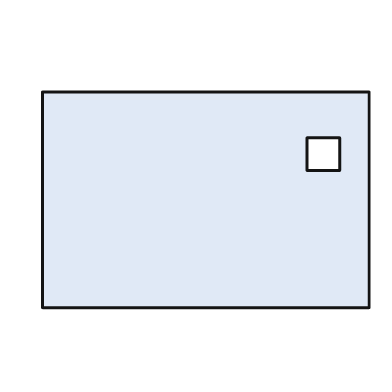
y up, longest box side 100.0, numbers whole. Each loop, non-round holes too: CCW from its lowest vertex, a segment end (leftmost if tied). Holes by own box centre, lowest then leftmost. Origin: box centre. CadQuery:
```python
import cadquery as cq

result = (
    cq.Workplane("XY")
    .moveTo(-50.0, -33.0)
    .lineTo(50.0, -33.0)
    .lineTo(50.0, 33.0)
    .lineTo(-50.0, 33.0)
    .close()
    .moveTo(31.0, 9.0)
    .lineTo(41.0, 9.0)
    .lineTo(41.0, 19.0)
    .lineTo(31.0, 19.0)
    .close()
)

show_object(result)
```